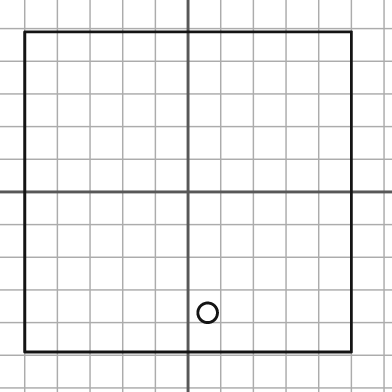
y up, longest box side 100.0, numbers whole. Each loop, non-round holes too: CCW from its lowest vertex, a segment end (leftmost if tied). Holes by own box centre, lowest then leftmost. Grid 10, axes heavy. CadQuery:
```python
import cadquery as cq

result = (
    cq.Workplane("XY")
    .moveTo(-50.0, -49.0)
    .lineTo(50.0, -49.0)
    .lineTo(50.0, 49.0)
    .lineTo(-50.0, 49.0)
    .close()
    .moveTo(6.0, -37.0)
    .circle(3.0)
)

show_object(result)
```